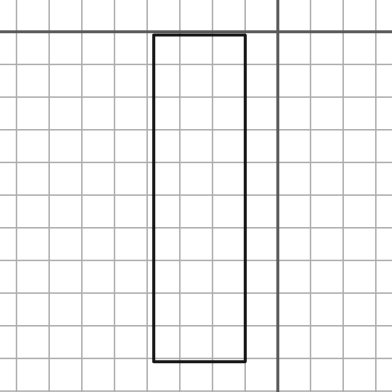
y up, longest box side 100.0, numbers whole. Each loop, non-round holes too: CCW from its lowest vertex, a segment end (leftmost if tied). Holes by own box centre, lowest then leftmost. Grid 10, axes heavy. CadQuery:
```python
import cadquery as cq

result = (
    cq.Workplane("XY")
    .moveTo(-38.0, -101.0)
    .lineTo(-10.0, -101.0)
    .lineTo(-10.0, -1.0)
    .lineTo(-38.0, -1.0)
    .close()
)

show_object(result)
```